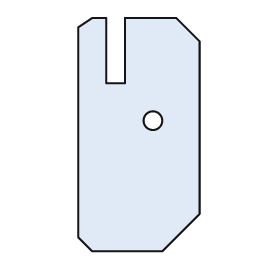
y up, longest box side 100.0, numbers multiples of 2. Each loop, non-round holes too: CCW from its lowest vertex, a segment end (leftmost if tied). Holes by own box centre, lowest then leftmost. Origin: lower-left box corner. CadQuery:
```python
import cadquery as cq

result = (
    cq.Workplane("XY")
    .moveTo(6.0, 0.0)
    .lineTo(36.0, 0.0)
    .lineTo(52.0, 16.0)
    .lineTo(52.0, 90.0)
    .lineTo(42.0, 100.0)
    .lineTo(20.0, 100.0)
    .lineTo(20.0, 72.0)
    .lineTo(12.0, 72.0)
    .lineTo(12.0, 100.0)
    .lineTo(6.0, 100.0)
    .lineTo(0.0, 96.0)
    .lineTo(0.0, 6.0)
    .close()
    .moveTo(32.0, 56.0)
    .circle(4.0)
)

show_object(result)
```